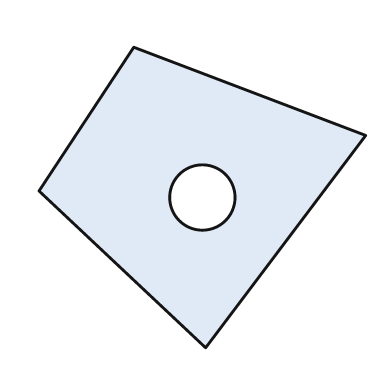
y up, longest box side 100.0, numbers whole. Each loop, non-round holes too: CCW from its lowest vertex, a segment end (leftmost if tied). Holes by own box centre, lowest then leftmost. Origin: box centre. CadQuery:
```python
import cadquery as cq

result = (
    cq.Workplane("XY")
    .moveTo(1.0, -46.0)
    .lineTo(50.0, 19.0)
    .lineTo(-21.0, 46.0)
    .lineTo(-50.0, 2.0)
    .close()
    .moveTo(0.0, 0.0)
    .circle(10.0)
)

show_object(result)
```